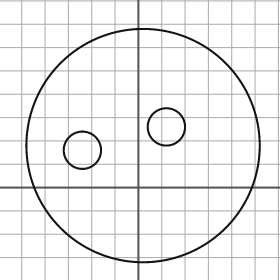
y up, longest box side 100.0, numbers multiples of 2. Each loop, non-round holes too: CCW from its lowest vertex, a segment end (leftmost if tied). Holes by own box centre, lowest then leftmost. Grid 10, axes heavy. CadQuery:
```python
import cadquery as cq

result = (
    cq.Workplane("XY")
    .moveTo(2.0, 18.0)
    .circle(50.0)
    .moveTo(-24.0, 16.0)
    .circle(8.0)
    .moveTo(12.0, 26.0)
    .circle(8.0)
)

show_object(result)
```